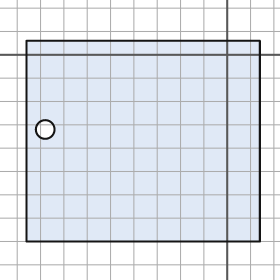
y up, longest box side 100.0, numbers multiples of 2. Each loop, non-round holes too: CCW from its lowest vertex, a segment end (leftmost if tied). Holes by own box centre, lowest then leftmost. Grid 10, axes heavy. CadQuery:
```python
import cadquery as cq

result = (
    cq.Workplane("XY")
    .moveTo(-86.0, -80.0)
    .lineTo(14.0, -80.0)
    .lineTo(14.0, 6.0)
    .lineTo(-86.0, 6.0)
    .close()
    .moveTo(-78.0, -32.0)
    .circle(4.0)
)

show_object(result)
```